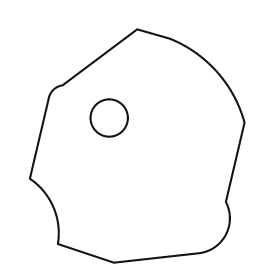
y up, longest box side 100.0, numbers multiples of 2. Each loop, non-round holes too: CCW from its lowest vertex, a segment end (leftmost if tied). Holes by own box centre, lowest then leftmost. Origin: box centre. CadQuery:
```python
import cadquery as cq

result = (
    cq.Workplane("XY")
    .moveTo(-10.0, -50.0)
    .lineTo(26.0, -46.0)
    .threePointArc((38.0, -38.0), (38.0, -24.0))
    .lineTo(46.0, 10.0)
    .threePointArc((34.0, 32.0), (14.0, 46.0))
    .lineTo(0.0, 50.0)
    .lineTo(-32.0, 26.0)
    .threePointArc((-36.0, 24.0), (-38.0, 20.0))
    .lineTo(-46.0, -14.0)
    .threePointArc((-36.0, -26.0), (-34.0, -42.0))
    .close()
    .moveTo(-12.0, 12.0)
    .circle(8.0)
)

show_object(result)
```